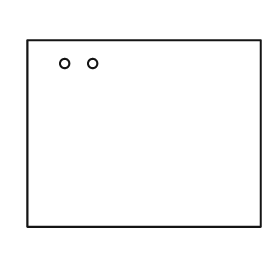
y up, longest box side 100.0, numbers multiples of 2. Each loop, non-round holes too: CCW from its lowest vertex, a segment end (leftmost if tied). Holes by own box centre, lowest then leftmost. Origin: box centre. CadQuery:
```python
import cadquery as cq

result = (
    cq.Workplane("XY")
    .moveTo(-50.0, -40.0)
    .lineTo(50.0, -40.0)
    .lineTo(50.0, 40.0)
    .lineTo(-50.0, 40.0)
    .close()
    .moveTo(-34.0, 30.0)
    .circle(2.0)
    .moveTo(-22.0, 30.0)
    .circle(2.0)
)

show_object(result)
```